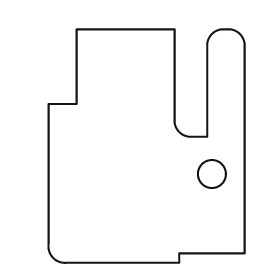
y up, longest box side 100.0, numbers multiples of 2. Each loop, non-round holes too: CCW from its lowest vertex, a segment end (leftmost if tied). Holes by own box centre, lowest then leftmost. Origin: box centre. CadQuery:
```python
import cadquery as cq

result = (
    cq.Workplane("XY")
    .moveTo(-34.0, -50.0)
    .lineTo(14.0, -50.0)
    .lineTo(14.0, -46.0)
    .lineTo(42.0, -46.0)
    .lineTo(42.0, 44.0)
    .threePointArc((40.0, 48.0), (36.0, 50.0))
    .lineTo(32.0, 50.0)
    .threePointArc((28.0, 48.0), (26.0, 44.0))
    .lineTo(26.0, 4.0)
    .lineTo(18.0, 4.0)
    .threePointArc((14.0, 6.0), (12.0, 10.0))
    .lineTo(12.0, 50.0)
    .lineTo(-30.0, 50.0)
    .lineTo(-30.0, 18.0)
    .lineTo(-42.0, 18.0)
    .lineTo(-42.0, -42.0)
    .threePointArc((-40.0, -48.0), (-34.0, -50.0))
    .close()
    .moveTo(28.0, -12.0)
    .circle(6.0)
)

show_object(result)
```